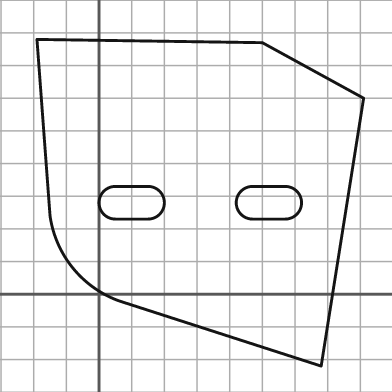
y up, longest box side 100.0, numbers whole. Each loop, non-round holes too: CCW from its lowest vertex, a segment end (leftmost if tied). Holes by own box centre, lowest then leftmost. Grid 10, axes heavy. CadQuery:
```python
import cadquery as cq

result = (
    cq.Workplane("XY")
    .moveTo(68.0, -22.0)
    .lineTo(81.0, 60.0)
    .lineTo(50.0, 77.0)
    .lineTo(-19.0, 78.0)
    .lineTo(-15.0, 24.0)
    .threePointArc((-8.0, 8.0), (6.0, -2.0))
    .close()
    .moveTo(5.0, 23.0)
    .lineTo(15.0, 23.0)
    .threePointArc((20.0, 28.0), (15.0, 33.0))
    .lineTo(5.0, 33.0)
    .threePointArc((0.0, 28.0), (5.0, 23.0))
    .close()
    .moveTo(47.0, 23.0)
    .lineTo(57.0, 23.0)
    .threePointArc((62.0, 28.0), (57.0, 33.0))
    .lineTo(47.0, 33.0)
    .threePointArc((42.0, 28.0), (47.0, 23.0))
    .close()
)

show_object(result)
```